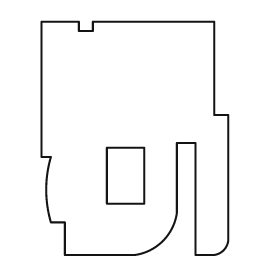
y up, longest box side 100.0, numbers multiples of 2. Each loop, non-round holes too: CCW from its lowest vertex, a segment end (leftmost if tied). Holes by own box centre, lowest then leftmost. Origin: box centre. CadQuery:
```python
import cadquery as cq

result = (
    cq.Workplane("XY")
    .moveTo(-30.0, -50.0)
    .lineTo(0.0, -50.0)
    .threePointArc((12.0, -44.0), (18.0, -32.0))
    .lineTo(18.0, -2.0)
    .lineTo(26.0, -2.0)
    .lineTo(26.0, -50.0)
    .lineTo(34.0, -50.0)
    .threePointArc((38.0, -48.0), (40.0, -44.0))
    .lineTo(40.0, 10.0)
    .lineTo(34.0, 10.0)
    .lineTo(34.0, 50.0)
    .lineTo(-18.0, 50.0)
    .lineTo(-18.0, 46.0)
    .lineTo(-24.0, 46.0)
    .lineTo(-24.0, 50.0)
    .lineTo(-40.0, 50.0)
    .lineTo(-40.0, -8.0)
    .lineTo(-36.0, -8.0)
    .threePointArc((-38.0, -22.0), (-36.0, -36.0))
    .lineTo(-30.0, -36.0)
    .close()
    .moveTo(-12.0, -28.0)
    .lineTo(4.0, -28.0)
    .lineTo(4.0, -4.0)
    .lineTo(-12.0, -4.0)
    .close()
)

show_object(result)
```